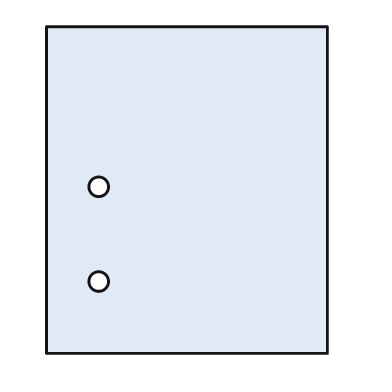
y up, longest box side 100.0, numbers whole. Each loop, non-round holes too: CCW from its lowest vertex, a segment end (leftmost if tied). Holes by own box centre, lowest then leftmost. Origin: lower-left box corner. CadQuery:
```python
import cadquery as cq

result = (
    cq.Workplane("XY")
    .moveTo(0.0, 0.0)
    .lineTo(86.0, 0.0)
    .lineTo(86.0, 100.0)
    .lineTo(0.0, 100.0)
    .close()
    .moveTo(16.0, 22.0)
    .circle(3.0)
    .moveTo(16.0, 51.0)
    .circle(3.0)
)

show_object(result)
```